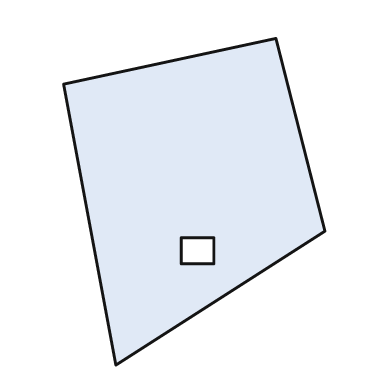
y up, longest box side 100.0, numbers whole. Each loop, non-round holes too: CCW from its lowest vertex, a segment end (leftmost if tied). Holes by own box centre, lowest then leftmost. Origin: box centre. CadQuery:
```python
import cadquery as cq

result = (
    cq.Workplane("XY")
    .moveTo(-24.0, -50.0)
    .lineTo(40.0, -9.0)
    .lineTo(25.0, 50.0)
    .lineTo(-40.0, 36.0)
    .close()
    .moveTo(-4.0, -19.0)
    .lineTo(6.0, -19.0)
    .lineTo(6.0, -11.0)
    .lineTo(-4.0, -11.0)
    .close()
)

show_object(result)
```